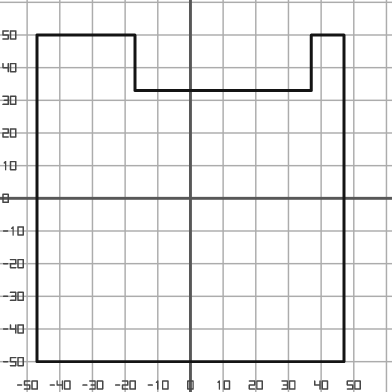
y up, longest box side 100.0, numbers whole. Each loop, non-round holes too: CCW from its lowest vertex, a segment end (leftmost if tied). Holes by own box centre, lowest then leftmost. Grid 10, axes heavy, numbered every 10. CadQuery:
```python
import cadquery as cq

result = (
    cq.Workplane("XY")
    .moveTo(-47.0, -50.0)
    .lineTo(47.0, -50.0)
    .lineTo(47.0, 50.0)
    .lineTo(37.0, 50.0)
    .lineTo(37.0, 33.0)
    .lineTo(-17.0, 33.0)
    .lineTo(-17.0, 50.0)
    .lineTo(-47.0, 50.0)
    .close()
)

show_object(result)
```